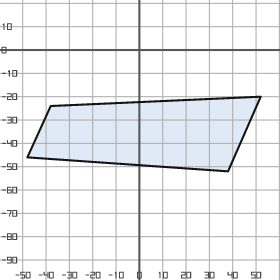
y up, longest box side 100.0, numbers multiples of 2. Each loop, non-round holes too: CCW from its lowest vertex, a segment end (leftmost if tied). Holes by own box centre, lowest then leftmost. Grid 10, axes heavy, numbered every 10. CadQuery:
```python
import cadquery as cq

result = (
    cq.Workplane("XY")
    .moveTo(38.0, -52.0)
    .lineTo(52.0, -20.0)
    .lineTo(-38.0, -24.0)
    .lineTo(-48.0, -46.0)
    .close()
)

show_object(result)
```